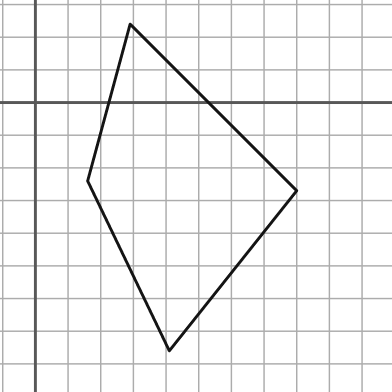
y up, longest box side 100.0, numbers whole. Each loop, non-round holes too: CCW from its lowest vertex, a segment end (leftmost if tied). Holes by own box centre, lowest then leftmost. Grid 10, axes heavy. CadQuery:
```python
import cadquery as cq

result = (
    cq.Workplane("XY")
    .moveTo(41.0, -76.0)
    .lineTo(80.0, -27.0)
    .lineTo(29.0, 24.0)
    .lineTo(16.0, -24.0)
    .close()
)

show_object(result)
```